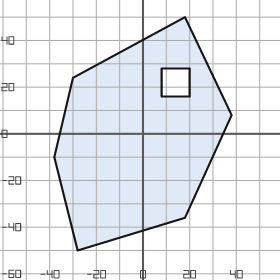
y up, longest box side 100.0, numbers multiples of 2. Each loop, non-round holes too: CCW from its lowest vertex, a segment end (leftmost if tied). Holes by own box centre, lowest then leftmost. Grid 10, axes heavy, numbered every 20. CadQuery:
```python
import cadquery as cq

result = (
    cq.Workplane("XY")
    .moveTo(-28.0, -50.0)
    .lineTo(18.0, -36.0)
    .lineTo(38.0, 8.0)
    .lineTo(18.0, 50.0)
    .lineTo(-30.0, 24.0)
    .lineTo(-38.0, -10.0)
    .close()
    .moveTo(8.0, 16.0)
    .lineTo(20.0, 16.0)
    .lineTo(20.0, 28.0)
    .lineTo(8.0, 28.0)
    .close()
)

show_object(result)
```